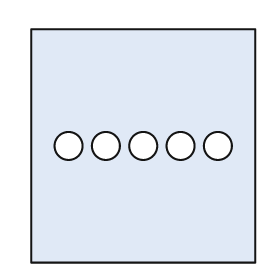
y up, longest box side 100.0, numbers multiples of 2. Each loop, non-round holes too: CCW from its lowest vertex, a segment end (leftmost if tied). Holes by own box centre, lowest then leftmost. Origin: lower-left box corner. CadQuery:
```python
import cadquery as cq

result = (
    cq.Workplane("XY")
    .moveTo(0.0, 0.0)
    .lineTo(96.0, 0.0)
    .lineTo(96.0, 100.0)
    .lineTo(0.0, 100.0)
    .close()
    .moveTo(16.0, 50.0)
    .circle(6.0)
    .moveTo(32.0, 50.0)
    .circle(6.0)
    .moveTo(48.0, 50.0)
    .circle(6.0)
    .moveTo(64.0, 50.0)
    .circle(6.0)
    .moveTo(80.0, 50.0)
    .circle(6.0)
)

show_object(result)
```